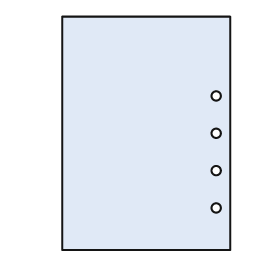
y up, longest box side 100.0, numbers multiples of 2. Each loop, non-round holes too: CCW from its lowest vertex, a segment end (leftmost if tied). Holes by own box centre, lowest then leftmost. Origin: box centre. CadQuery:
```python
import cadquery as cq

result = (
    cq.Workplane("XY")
    .moveTo(-36.0, -50.0)
    .lineTo(36.0, -50.0)
    .lineTo(36.0, 50.0)
    .lineTo(-36.0, 50.0)
    .close()
    .moveTo(30.0, -32.0)
    .circle(2.0)
    .moveTo(30.0, -16.0)
    .circle(2.0)
    .moveTo(30.0, 0.0)
    .circle(2.0)
    .moveTo(30.0, 16.0)
    .circle(2.0)
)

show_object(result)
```